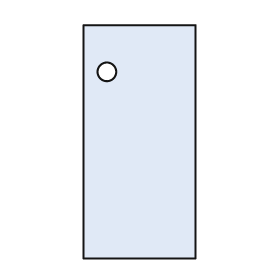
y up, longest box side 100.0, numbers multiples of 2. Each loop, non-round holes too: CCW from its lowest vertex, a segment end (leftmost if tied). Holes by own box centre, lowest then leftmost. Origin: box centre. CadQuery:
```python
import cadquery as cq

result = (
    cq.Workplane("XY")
    .moveTo(-24.0, -50.0)
    .lineTo(24.0, -50.0)
    .lineTo(24.0, 50.0)
    .lineTo(-24.0, 50.0)
    .close()
    .moveTo(-14.0, 30.0)
    .circle(4.0)
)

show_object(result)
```